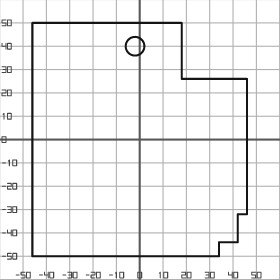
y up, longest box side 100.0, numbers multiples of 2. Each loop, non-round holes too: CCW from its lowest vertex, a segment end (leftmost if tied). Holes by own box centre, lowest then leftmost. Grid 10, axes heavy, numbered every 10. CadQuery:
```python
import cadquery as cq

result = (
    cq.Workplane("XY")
    .moveTo(-46.0, -50.0)
    .lineTo(34.0, -50.0)
    .lineTo(34.0, -44.0)
    .lineTo(42.0, -44.0)
    .lineTo(42.0, -32.0)
    .lineTo(46.0, -32.0)
    .lineTo(46.0, 26.0)
    .lineTo(18.0, 26.0)
    .lineTo(18.0, 50.0)
    .lineTo(-46.0, 50.0)
    .close()
    .moveTo(-2.0, 40.0)
    .circle(4.0)
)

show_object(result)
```